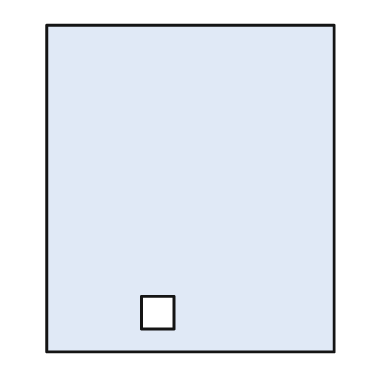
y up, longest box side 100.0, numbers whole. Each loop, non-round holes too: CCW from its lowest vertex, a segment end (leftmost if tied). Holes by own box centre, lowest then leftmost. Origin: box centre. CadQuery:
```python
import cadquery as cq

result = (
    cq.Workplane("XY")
    .moveTo(-44.0, -50.0)
    .lineTo(44.0, -50.0)
    .lineTo(44.0, 50.0)
    .lineTo(-44.0, 50.0)
    .close()
    .moveTo(-15.0, -43.0)
    .lineTo(-5.0, -43.0)
    .lineTo(-5.0, -33.0)
    .lineTo(-15.0, -33.0)
    .close()
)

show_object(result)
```